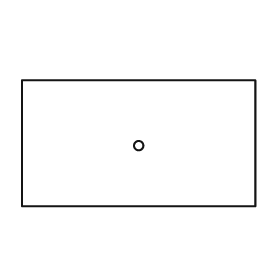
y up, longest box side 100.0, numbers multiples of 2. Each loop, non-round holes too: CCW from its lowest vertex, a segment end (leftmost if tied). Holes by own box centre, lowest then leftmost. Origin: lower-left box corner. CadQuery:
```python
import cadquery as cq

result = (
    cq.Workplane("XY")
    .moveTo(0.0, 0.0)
    .lineTo(100.0, 0.0)
    .lineTo(100.0, 54.0)
    .lineTo(0.0, 54.0)
    .close()
    .moveTo(50.0, 26.0)
    .circle(2.0)
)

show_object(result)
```